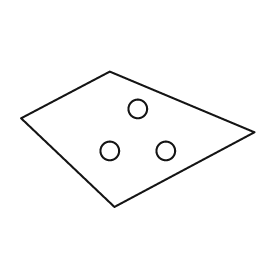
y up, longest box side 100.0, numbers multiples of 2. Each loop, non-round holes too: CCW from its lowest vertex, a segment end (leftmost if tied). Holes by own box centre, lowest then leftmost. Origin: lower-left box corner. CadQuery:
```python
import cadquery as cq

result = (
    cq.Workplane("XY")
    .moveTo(40.0, 0.0)
    .lineTo(100.0, 32.0)
    .lineTo(38.0, 58.0)
    .lineTo(0.0, 38.0)
    .close()
    .moveTo(38.0, 24.0)
    .circle(4.0)
    .moveTo(62.0, 24.0)
    .circle(4.0)
    .moveTo(50.0, 42.0)
    .circle(4.0)
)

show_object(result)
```